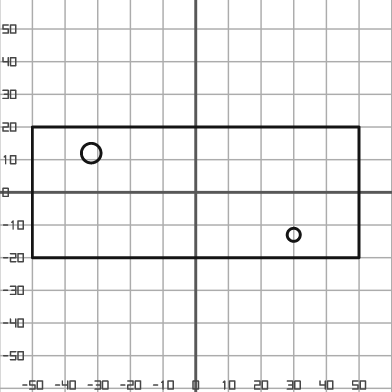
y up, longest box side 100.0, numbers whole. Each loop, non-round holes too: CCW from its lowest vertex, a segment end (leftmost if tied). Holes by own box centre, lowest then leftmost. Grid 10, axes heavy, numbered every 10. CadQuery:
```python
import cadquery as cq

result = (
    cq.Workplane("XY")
    .moveTo(-50.0, -20.0)
    .lineTo(50.0, -20.0)
    .lineTo(50.0, 20.0)
    .lineTo(-50.0, 20.0)
    .close()
    .moveTo(30.0, -13.0)
    .circle(2.0)
    .moveTo(-32.0, 12.0)
    .circle(3.0)
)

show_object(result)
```